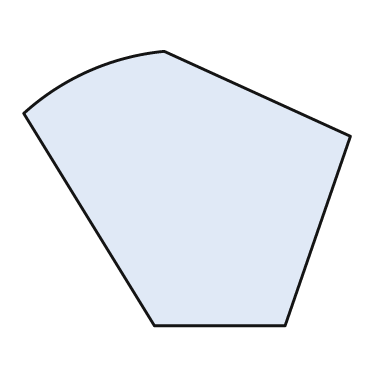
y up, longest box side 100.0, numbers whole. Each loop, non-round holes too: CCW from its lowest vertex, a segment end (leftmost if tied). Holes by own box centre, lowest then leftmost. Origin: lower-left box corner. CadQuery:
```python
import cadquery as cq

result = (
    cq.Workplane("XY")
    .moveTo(40.0, 0.0)
    .lineTo(80.0, 0.0)
    .lineTo(100.0, 58.0)
    .lineTo(43.0, 84.0)
    .threePointArc((20.0, 78.0), (0.0, 65.0))
    .close()
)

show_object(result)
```